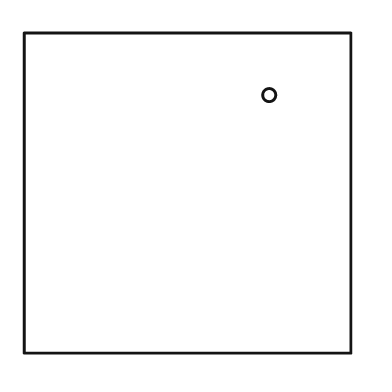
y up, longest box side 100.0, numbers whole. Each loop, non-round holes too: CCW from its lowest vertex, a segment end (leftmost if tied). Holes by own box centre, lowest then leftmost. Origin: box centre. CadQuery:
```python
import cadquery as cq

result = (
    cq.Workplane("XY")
    .moveTo(-50.0, -49.0)
    .lineTo(50.0, -49.0)
    .lineTo(50.0, 49.0)
    .lineTo(-50.0, 49.0)
    .close()
    .moveTo(25.0, 30.0)
    .circle(2.0)
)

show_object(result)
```